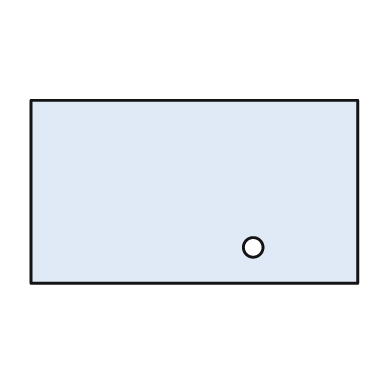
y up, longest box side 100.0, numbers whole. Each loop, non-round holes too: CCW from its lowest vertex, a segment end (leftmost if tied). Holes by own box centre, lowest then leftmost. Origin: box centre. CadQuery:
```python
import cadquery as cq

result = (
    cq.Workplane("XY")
    .moveTo(-50.0, -28.0)
    .lineTo(50.0, -28.0)
    .lineTo(50.0, 28.0)
    .lineTo(-50.0, 28.0)
    .close()
    .moveTo(18.0, -17.0)
    .circle(3.0)
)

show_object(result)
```